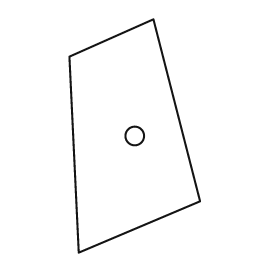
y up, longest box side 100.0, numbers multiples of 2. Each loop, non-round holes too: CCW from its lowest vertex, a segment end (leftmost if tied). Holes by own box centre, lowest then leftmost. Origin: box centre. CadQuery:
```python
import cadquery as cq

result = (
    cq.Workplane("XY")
    .moveTo(-24.0, -50.0)
    .lineTo(28.0, -28.0)
    .lineTo(8.0, 50.0)
    .lineTo(-28.0, 34.0)
    .close()
    .moveTo(0.0, 0.0)
    .circle(4.0)
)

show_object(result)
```